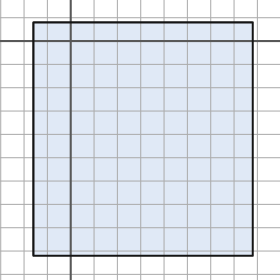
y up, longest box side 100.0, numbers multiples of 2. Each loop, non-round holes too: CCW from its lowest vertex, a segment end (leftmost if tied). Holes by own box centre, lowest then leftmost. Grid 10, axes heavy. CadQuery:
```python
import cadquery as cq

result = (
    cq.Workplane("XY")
    .moveTo(-16.0, -92.0)
    .lineTo(78.0, -92.0)
    .lineTo(78.0, 8.0)
    .lineTo(-16.0, 8.0)
    .close()
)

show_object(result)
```